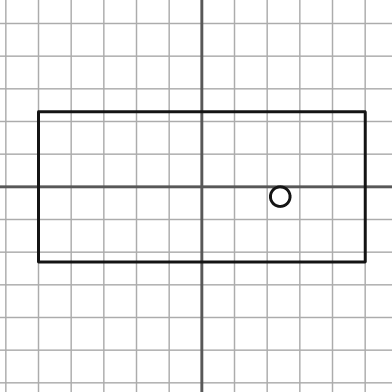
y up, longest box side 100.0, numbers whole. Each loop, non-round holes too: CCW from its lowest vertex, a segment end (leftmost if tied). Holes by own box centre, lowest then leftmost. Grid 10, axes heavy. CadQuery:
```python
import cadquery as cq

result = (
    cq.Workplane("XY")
    .moveTo(-50.0, -23.0)
    .lineTo(50.0, -23.0)
    .lineTo(50.0, 23.0)
    .lineTo(-50.0, 23.0)
    .close()
    .moveTo(24.0, -3.0)
    .circle(3.0)
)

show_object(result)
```